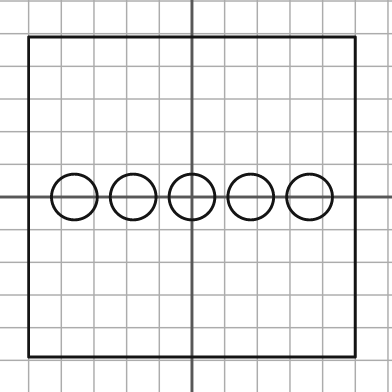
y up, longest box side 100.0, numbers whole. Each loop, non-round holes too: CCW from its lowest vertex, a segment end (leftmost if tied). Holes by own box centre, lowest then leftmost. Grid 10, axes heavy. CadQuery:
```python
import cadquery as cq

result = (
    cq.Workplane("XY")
    .moveTo(-50.0, -49.0)
    .lineTo(50.0, -49.0)
    .lineTo(50.0, 49.0)
    .lineTo(-50.0, 49.0)
    .close()
    .moveTo(-36.0, 0.0)
    .circle(7.0)
    .moveTo(-18.0, 0.0)
    .circle(7.0)
    .moveTo(0.0, 0.0)
    .circle(7.0)
    .moveTo(18.0, 0.0)
    .circle(7.0)
    .moveTo(36.0, 0.0)
    .circle(7.0)
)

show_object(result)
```